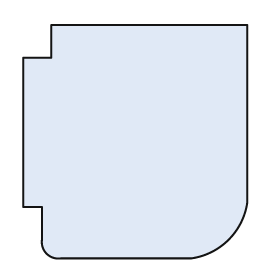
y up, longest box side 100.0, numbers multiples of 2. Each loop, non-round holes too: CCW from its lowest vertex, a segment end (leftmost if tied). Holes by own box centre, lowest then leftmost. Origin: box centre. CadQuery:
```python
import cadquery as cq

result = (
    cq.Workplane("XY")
    .moveTo(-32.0, -50.0)
    .lineTo(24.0, -50.0)
    .threePointArc((40.0, -42.0), (48.0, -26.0))
    .lineTo(48.0, 50.0)
    .lineTo(-36.0, 50.0)
    .lineTo(-36.0, 36.0)
    .lineTo(-48.0, 36.0)
    .lineTo(-48.0, -28.0)
    .lineTo(-40.0, -28.0)
    .lineTo(-40.0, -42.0)
    .threePointArc((-38.0, -48.0), (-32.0, -50.0))
    .close()
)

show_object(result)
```